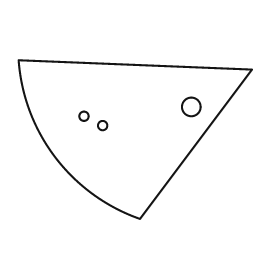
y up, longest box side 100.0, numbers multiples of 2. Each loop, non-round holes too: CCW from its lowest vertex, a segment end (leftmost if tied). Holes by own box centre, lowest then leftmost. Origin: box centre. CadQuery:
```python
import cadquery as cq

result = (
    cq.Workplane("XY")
    .moveTo(2.0, -34.0)
    .lineTo(50.0, 30.0)
    .lineTo(-50.0, 34.0)
    .threePointArc((-34.0, -8.0), (2.0, -34.0))
    .close()
    .moveTo(-14.0, 6.0)
    .circle(2.0)
    .moveTo(-22.0, 10.0)
    .circle(2.0)
    .moveTo(24.0, 14.0)
    .circle(4.0)
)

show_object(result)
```